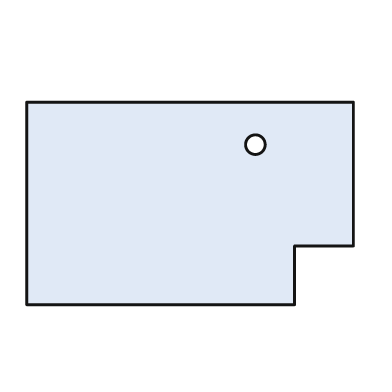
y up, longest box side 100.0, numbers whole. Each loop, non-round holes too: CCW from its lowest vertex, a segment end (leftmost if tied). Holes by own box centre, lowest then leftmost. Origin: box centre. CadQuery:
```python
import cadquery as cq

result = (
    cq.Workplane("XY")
    .moveTo(-50.0, -31.0)
    .lineTo(32.0, -31.0)
    .lineTo(32.0, -13.0)
    .lineTo(50.0, -13.0)
    .lineTo(50.0, 31.0)
    .lineTo(-50.0, 31.0)
    .close()
    .moveTo(20.0, 18.0)
    .circle(3.0)
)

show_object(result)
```